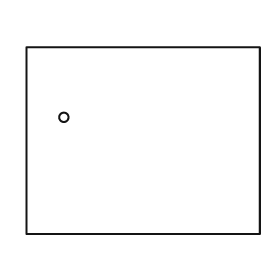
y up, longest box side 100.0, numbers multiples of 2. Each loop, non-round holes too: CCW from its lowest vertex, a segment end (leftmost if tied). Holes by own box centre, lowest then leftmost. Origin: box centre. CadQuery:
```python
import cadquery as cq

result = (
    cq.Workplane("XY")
    .moveTo(-50.0, -40.0)
    .lineTo(50.0, -40.0)
    .lineTo(50.0, 40.0)
    .lineTo(-50.0, 40.0)
    .close()
    .moveTo(-34.0, 10.0)
    .circle(2.0)
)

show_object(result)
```